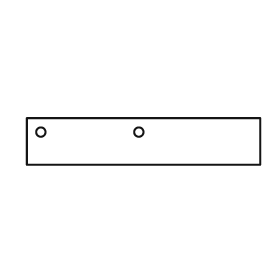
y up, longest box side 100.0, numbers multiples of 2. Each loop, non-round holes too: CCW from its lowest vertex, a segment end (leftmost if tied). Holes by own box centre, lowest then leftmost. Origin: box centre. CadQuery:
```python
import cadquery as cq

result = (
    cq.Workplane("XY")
    .moveTo(-50.0, -10.0)
    .lineTo(50.0, -10.0)
    .lineTo(50.0, 10.0)
    .lineTo(-50.0, 10.0)
    .close()
    .moveTo(-44.0, 4.0)
    .circle(2.0)
    .moveTo(-2.0, 4.0)
    .circle(2.0)
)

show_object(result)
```